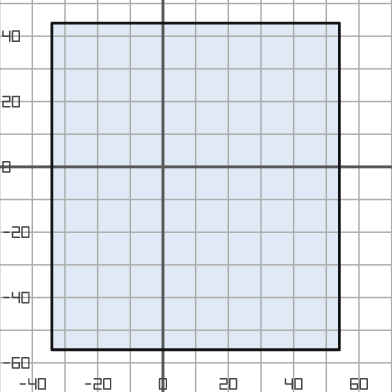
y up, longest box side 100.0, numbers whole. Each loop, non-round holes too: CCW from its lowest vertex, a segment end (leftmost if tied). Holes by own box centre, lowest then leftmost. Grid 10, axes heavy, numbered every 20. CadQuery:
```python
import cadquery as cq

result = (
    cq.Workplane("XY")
    .moveTo(-34.0, -56.0)
    .lineTo(54.0, -56.0)
    .lineTo(54.0, 44.0)
    .lineTo(-34.0, 44.0)
    .close()
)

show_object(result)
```